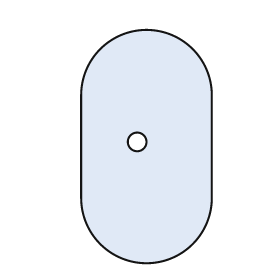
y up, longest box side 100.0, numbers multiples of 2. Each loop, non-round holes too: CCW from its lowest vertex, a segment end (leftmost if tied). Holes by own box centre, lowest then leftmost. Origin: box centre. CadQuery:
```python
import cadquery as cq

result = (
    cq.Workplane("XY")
    .moveTo(-28.0, -22.0)
    .threePointArc((0.0, -50.0), (28.0, -22.0))
    .lineTo(28.0, 22.0)
    .threePointArc((0.0, 50.0), (-28.0, 22.0))
    .close()
    .moveTo(-4.0, 2.0)
    .circle(4.0)
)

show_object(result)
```